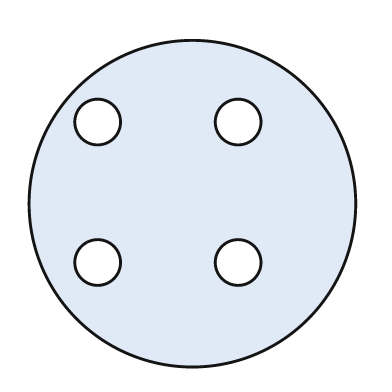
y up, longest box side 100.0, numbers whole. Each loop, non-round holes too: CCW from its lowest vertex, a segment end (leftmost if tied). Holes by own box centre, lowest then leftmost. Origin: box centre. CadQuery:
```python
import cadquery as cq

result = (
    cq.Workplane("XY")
    .moveTo(0.0, 0.0)
    .circle(50.0)
    .moveTo(-29.0, -18.0)
    .circle(7.0)
    .moveTo(14.0, -18.0)
    .circle(7.0)
    .moveTo(-29.0, 25.0)
    .circle(7.0)
    .moveTo(14.0, 25.0)
    .circle(7.0)
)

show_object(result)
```